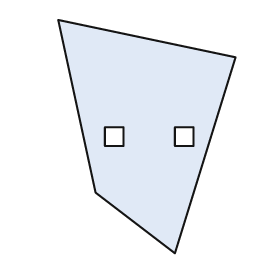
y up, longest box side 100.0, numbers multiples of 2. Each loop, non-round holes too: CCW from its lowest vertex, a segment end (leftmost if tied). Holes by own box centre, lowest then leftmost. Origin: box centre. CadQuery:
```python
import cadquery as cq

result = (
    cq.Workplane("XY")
    .moveTo(12.0, -50.0)
    .lineTo(38.0, 34.0)
    .lineTo(-38.0, 50.0)
    .lineTo(-22.0, -24.0)
    .close()
    .moveTo(-18.0, -4.0)
    .lineTo(-10.0, -4.0)
    .lineTo(-10.0, 4.0)
    .lineTo(-18.0, 4.0)
    .close()
    .moveTo(12.0, -4.0)
    .lineTo(20.0, -4.0)
    .lineTo(20.0, 4.0)
    .lineTo(12.0, 4.0)
    .close()
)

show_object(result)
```